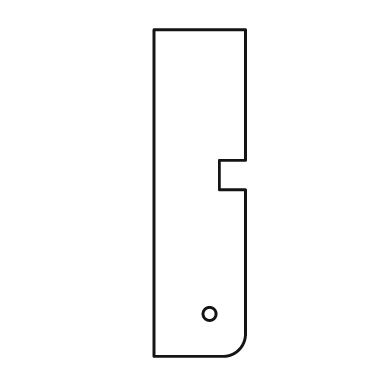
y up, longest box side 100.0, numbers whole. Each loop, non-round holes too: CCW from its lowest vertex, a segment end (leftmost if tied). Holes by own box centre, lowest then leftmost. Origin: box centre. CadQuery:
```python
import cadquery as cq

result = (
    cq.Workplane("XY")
    .moveTo(-14.0, -50.0)
    .lineTo(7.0, -50.0)
    .threePointArc((12.0, -48.0), (14.0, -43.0))
    .lineTo(14.0, 1.0)
    .lineTo(6.0, 1.0)
    .lineTo(6.0, 10.0)
    .lineTo(14.0, 10.0)
    .lineTo(14.0, 50.0)
    .lineTo(-14.0, 50.0)
    .close()
    .moveTo(3.0, -37.0)
    .circle(2.0)
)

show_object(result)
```